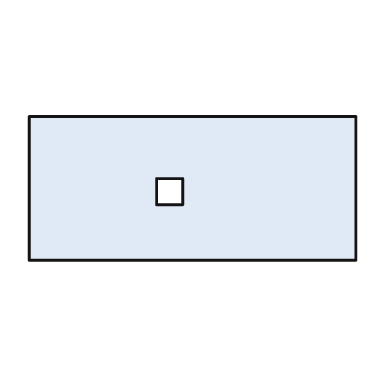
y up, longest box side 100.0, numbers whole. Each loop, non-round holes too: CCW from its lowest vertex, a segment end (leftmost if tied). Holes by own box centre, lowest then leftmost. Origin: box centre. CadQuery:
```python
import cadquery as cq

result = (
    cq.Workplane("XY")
    .moveTo(-50.0, -22.0)
    .lineTo(50.0, -22.0)
    .lineTo(50.0, 22.0)
    .lineTo(-50.0, 22.0)
    .close()
    .moveTo(-11.0, -5.0)
    .lineTo(-3.0, -5.0)
    .lineTo(-3.0, 3.0)
    .lineTo(-11.0, 3.0)
    .close()
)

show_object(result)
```